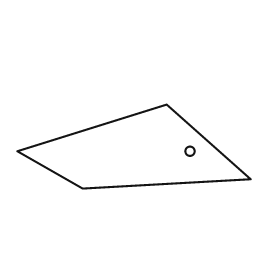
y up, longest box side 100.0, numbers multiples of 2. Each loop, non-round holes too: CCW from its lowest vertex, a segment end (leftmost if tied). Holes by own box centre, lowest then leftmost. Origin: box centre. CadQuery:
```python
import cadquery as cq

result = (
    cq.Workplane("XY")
    .moveTo(-22.0, -18.0)
    .lineTo(50.0, -14.0)
    .lineTo(14.0, 18.0)
    .lineTo(-50.0, -2.0)
    .close()
    .moveTo(24.0, -2.0)
    .circle(2.0)
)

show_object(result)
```